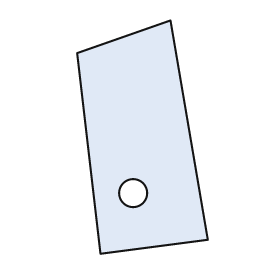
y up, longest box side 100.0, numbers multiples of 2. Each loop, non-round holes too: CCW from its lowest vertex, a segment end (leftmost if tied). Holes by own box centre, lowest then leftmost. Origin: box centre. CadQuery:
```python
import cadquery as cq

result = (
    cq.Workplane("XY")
    .moveTo(-18.0, -50.0)
    .lineTo(28.0, -44.0)
    .lineTo(12.0, 50.0)
    .lineTo(-28.0, 36.0)
    .close()
    .moveTo(-4.0, -24.0)
    .circle(6.0)
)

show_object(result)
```